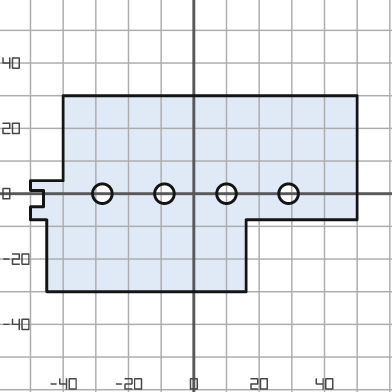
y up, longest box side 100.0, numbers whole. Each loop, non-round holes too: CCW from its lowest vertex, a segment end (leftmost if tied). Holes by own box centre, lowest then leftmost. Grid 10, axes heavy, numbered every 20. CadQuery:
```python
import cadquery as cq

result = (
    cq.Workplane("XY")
    .moveTo(-45.0, -30.0)
    .lineTo(16.0, -30.0)
    .lineTo(16.0, -8.0)
    .lineTo(50.0, -8.0)
    .lineTo(50.0, 30.0)
    .lineTo(-40.0, 30.0)
    .lineTo(-40.0, 4.0)
    .lineTo(-50.0, 4.0)
    .lineTo(-50.0, 1.0)
    .lineTo(-46.0, 1.0)
    .lineTo(-46.0, -4.0)
    .lineTo(-50.0, -4.0)
    .lineTo(-50.0, -8.0)
    .lineTo(-45.0, -8.0)
    .close()
    .moveTo(-28.0, 0.0)
    .circle(3.0)
    .moveTo(-9.0, 0.0)
    .circle(3.0)
    .moveTo(10.0, 0.0)
    .circle(3.0)
    .moveTo(29.0, 0.0)
    .circle(3.0)
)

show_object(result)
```